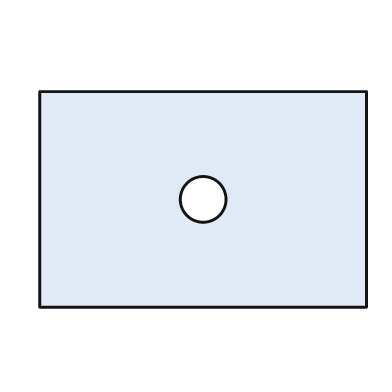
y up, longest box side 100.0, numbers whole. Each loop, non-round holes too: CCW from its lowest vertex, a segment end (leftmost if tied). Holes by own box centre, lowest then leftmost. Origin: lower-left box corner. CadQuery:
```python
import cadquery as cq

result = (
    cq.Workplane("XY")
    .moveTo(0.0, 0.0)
    .lineTo(100.0, 0.0)
    .lineTo(100.0, 66.0)
    .lineTo(0.0, 66.0)
    .close()
    .moveTo(50.0, 33.0)
    .circle(7.0)
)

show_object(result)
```